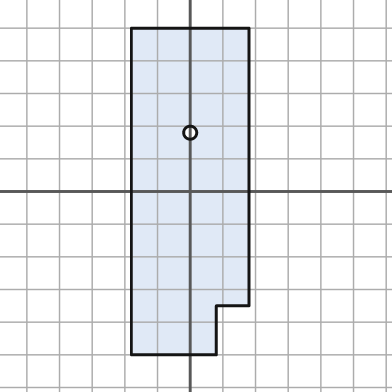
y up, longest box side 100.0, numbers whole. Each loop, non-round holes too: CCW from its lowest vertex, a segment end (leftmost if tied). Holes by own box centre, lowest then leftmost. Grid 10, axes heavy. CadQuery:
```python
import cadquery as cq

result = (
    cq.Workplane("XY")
    .moveTo(-18.0, -50.0)
    .lineTo(8.0, -50.0)
    .lineTo(8.0, -35.0)
    .lineTo(18.0, -35.0)
    .lineTo(18.0, 50.0)
    .lineTo(-18.0, 50.0)
    .close()
    .moveTo(0.0, 18.0)
    .circle(2.0)
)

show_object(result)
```